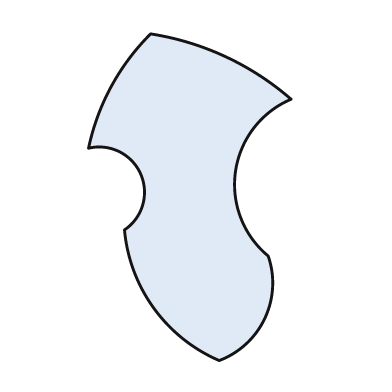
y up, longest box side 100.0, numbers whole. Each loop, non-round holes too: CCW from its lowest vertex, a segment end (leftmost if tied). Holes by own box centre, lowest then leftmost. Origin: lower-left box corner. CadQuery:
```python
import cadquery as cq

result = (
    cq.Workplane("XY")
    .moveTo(40.0, 0.0)
    .threePointArc((54.0, 13.0), (55.0, 32.0))
    .threePointArc((45.0, 58.0), (62.0, 80.0))
    .threePointArc((42.0, 93.0), (19.0, 100.0))
    .threePointArc((7.0, 84.0), (0.0, 65.0))
    .threePointArc((16.0, 57.0), (11.0, 40.0))
    .threePointArc((20.0, 16.0), (40.0, 0.0))
    .close()
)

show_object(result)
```